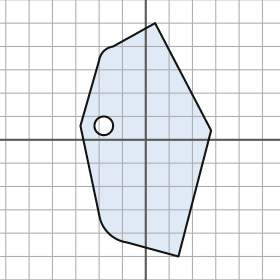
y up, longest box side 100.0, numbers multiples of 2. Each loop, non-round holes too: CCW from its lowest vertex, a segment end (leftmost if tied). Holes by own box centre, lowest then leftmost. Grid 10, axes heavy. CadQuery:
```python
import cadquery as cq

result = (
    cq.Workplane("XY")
    .moveTo(14.0, -50.0)
    .lineTo(28.0, 4.0)
    .lineTo(4.0, 50.0)
    .lineTo(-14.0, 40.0)
    .threePointArc((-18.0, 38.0), (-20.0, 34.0))
    .lineTo(-28.0, 6.0)
    .lineTo(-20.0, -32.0)
    .threePointArc((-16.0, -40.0), (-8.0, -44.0))
    .close()
    .moveTo(-18.0, 6.0)
    .circle(4.0)
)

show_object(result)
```